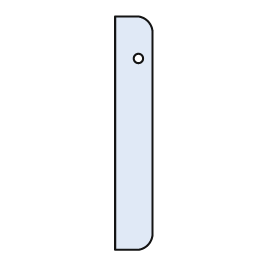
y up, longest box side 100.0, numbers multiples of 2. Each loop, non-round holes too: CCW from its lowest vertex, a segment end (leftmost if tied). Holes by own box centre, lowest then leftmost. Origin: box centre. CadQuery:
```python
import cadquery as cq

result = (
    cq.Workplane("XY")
    .moveTo(-8.0, -50.0)
    .lineTo(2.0, -50.0)
    .threePointArc((6.0, -48.0), (8.0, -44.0))
    .lineTo(8.0, 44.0)
    .threePointArc((6.0, 48.0), (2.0, 50.0))
    .lineTo(-8.0, 50.0)
    .close()
    .moveTo(2.0, 32.0)
    .circle(2.0)
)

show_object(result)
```